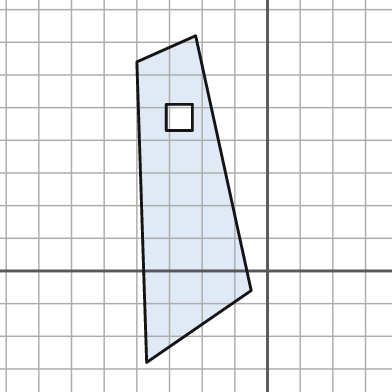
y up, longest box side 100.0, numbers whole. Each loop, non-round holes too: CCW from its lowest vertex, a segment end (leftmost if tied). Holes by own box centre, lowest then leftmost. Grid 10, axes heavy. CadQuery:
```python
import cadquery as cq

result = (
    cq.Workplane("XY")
    .moveTo(-37.0, -28.0)
    .lineTo(-5.0, -6.0)
    .lineTo(-22.0, 72.0)
    .lineTo(-40.0, 64.0)
    .close()
    .moveTo(-31.0, 43.0)
    .lineTo(-23.0, 43.0)
    .lineTo(-23.0, 51.0)
    .lineTo(-31.0, 51.0)
    .close()
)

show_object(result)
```